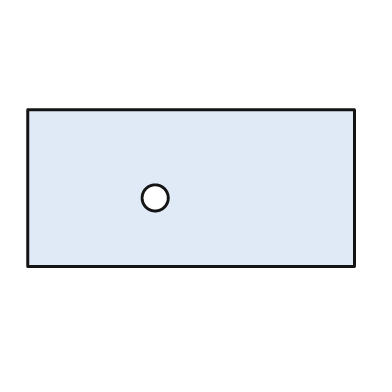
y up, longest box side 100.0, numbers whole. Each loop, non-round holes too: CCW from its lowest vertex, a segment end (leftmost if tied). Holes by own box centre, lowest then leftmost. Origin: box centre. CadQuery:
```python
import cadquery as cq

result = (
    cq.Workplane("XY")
    .moveTo(-50.0, -24.0)
    .lineTo(50.0, -24.0)
    .lineTo(50.0, 24.0)
    .lineTo(-50.0, 24.0)
    .close()
    .moveTo(-11.0, -3.0)
    .circle(4.0)
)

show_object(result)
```